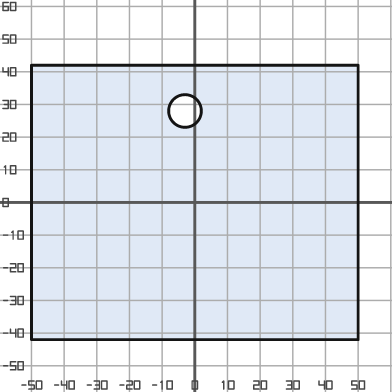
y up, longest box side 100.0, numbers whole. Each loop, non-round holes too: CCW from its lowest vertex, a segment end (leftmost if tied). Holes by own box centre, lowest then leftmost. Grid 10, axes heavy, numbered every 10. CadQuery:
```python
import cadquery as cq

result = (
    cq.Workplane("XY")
    .moveTo(-50.0, -42.0)
    .lineTo(50.0, -42.0)
    .lineTo(50.0, 42.0)
    .lineTo(-50.0, 42.0)
    .close()
    .moveTo(-3.0, 28.0)
    .circle(5.0)
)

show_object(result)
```